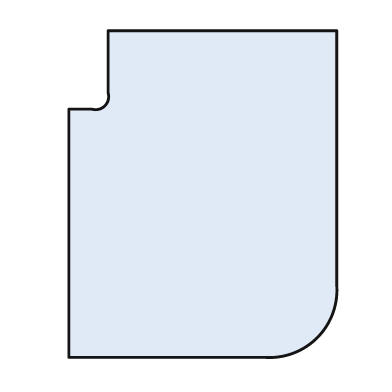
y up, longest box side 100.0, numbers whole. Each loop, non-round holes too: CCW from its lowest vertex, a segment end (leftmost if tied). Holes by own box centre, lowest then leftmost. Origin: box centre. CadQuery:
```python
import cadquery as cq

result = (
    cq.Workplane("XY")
    .moveTo(-41.0, -50.0)
    .lineTo(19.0, -50.0)
    .threePointArc((35.0, -44.0), (41.0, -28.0))
    .lineTo(41.0, 50.0)
    .lineTo(-29.0, 50.0)
    .lineTo(-29.0, 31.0)
    .threePointArc((-30.0, 27.0), (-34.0, 26.0))
    .lineTo(-41.0, 26.0)
    .close()
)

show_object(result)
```